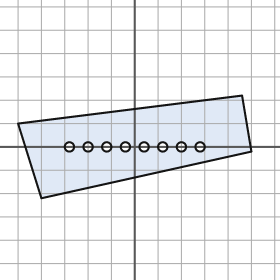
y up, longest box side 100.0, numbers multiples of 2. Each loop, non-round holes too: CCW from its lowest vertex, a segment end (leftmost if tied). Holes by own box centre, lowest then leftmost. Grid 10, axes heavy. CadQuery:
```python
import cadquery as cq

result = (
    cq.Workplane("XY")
    .moveTo(-40.0, -22.0)
    .lineTo(50.0, -2.0)
    .lineTo(46.0, 22.0)
    .lineTo(-50.0, 10.0)
    .close()
    .moveTo(-28.0, 0.0)
    .circle(2.0)
    .moveTo(-20.0, 0.0)
    .circle(2.0)
    .moveTo(-12.0, 0.0)
    .circle(2.0)
    .moveTo(-4.0, 0.0)
    .circle(2.0)
    .moveTo(4.0, 0.0)
    .circle(2.0)
    .moveTo(12.0, 0.0)
    .circle(2.0)
    .moveTo(20.0, 0.0)
    .circle(2.0)
    .moveTo(28.0, 0.0)
    .circle(2.0)
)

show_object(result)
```